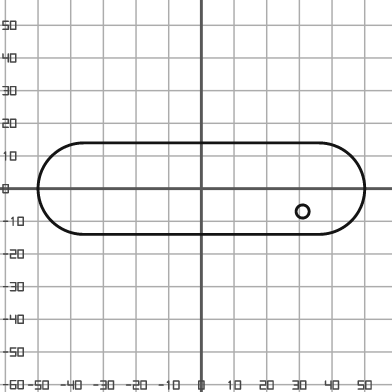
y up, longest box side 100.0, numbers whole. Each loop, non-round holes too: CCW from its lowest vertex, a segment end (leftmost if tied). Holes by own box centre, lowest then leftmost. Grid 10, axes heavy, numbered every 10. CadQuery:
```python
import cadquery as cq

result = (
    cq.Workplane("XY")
    .moveTo(-36.0, -14.0)
    .lineTo(36.0, -14.0)
    .threePointArc((50.0, 0.0), (36.0, 14.0))
    .lineTo(-36.0, 14.0)
    .threePointArc((-50.0, 0.0), (-36.0, -14.0))
    .close()
    .moveTo(31.0, -7.0)
    .circle(2.0)
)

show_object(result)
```